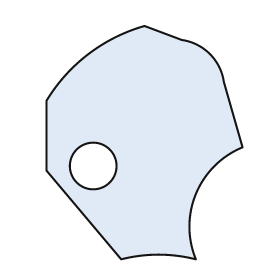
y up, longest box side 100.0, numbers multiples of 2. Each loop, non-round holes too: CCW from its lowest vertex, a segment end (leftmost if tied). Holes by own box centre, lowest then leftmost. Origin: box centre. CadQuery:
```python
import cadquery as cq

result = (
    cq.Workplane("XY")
    .moveTo(-10.0, -50.0)
    .threePointArc((6.0, -48.0), (22.0, -50.0))
    .threePointArc((22.0, -22.0), (42.0, -2.0))
    .lineTo(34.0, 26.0)
    .threePointArc((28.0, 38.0), (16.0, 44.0))
    .lineTo(0.0, 50.0)
    .threePointArc((-24.0, 38.0), (-42.0, 18.0))
    .lineTo(-42.0, -12.0)
    .close()
    .moveTo(-22.0, -10.0)
    .circle(10.0)
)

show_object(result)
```